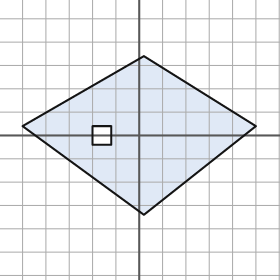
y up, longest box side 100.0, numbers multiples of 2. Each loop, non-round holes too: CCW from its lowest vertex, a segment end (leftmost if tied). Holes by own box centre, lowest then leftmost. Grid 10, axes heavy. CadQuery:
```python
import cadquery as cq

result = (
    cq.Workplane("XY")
    .moveTo(2.0, -34.0)
    .lineTo(50.0, 4.0)
    .lineTo(2.0, 34.0)
    .lineTo(-50.0, 4.0)
    .close()
    .moveTo(-20.0, -4.0)
    .lineTo(-12.0, -4.0)
    .lineTo(-12.0, 4.0)
    .lineTo(-20.0, 4.0)
    .close()
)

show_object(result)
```